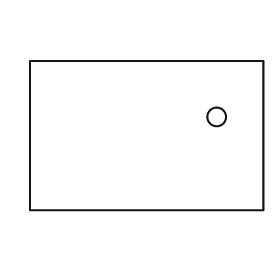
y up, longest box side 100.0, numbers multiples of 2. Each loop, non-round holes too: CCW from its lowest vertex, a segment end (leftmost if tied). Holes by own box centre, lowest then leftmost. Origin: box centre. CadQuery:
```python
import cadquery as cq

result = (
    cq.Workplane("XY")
    .moveTo(-50.0, -32.0)
    .lineTo(50.0, -32.0)
    .lineTo(50.0, 32.0)
    .lineTo(-50.0, 32.0)
    .close()
    .moveTo(30.0, 8.0)
    .circle(4.0)
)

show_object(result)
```